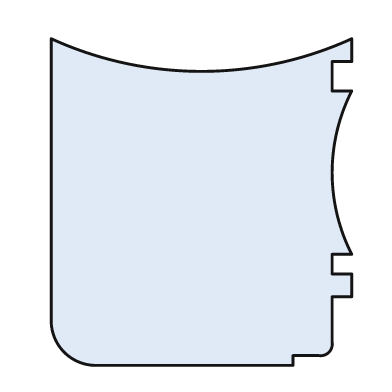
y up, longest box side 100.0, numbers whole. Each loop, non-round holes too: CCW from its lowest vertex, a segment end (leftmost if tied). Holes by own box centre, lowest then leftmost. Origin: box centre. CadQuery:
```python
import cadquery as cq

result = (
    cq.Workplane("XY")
    .moveTo(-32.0, -50.0)
    .lineTo(28.0, -50.0)
    .lineTo(28.0, -47.0)
    .lineTo(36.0, -47.0)
    .threePointArc((39.0, -46.0), (40.0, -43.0))
    .lineTo(40.0, -29.0)
    .lineTo(46.0, -29.0)
    .lineTo(46.0, -22.0)
    .lineTo(40.0, -22.0)
    .lineTo(40.0, -16.0)
    .lineTo(46.0, -16.0)
    .threePointArc((40.0, 9.0), (46.0, 34.0))
    .lineTo(40.0, 34.0)
    .lineTo(40.0, 43.0)
    .lineTo(46.0, 43.0)
    .lineTo(46.0, 50.0)
    .threePointArc((0.0, 40.0), (-46.0, 50.0))
    .lineTo(-46.0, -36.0)
    .threePointArc((-42.0, -46.0), (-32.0, -50.0))
    .close()
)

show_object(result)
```